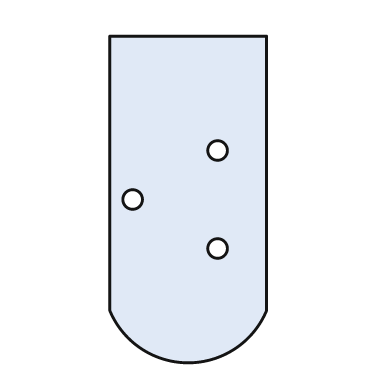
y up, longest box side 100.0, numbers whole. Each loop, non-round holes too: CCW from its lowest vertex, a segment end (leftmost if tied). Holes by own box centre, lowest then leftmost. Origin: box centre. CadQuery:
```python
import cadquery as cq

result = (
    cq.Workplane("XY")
    .moveTo(-24.0, -34.0)
    .threePointArc((0.0, -50.0), (24.0, -34.0))
    .lineTo(24.0, 50.0)
    .lineTo(-24.0, 50.0)
    .close()
    .moveTo(9.0, -15.0)
    .circle(3.0)
    .moveTo(-17.0, 0.0)
    .circle(3.0)
    .moveTo(9.0, 15.0)
    .circle(3.0)
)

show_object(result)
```